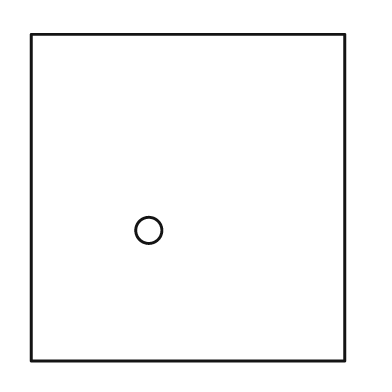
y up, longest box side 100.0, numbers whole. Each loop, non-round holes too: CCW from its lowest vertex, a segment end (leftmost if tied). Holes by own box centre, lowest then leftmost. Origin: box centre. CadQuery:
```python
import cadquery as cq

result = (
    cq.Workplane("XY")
    .moveTo(-48.0, -50.0)
    .lineTo(48.0, -50.0)
    .lineTo(48.0, 50.0)
    .lineTo(-48.0, 50.0)
    .close()
    .moveTo(-12.0, -10.0)
    .circle(4.0)
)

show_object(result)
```